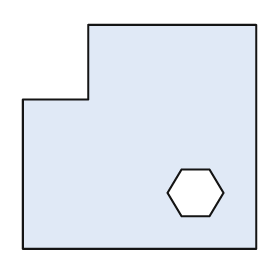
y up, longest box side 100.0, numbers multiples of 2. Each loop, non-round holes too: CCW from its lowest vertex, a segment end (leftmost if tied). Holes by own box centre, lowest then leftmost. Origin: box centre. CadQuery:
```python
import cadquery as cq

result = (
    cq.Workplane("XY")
    .moveTo(-50.0, -48.0)
    .lineTo(50.0, -48.0)
    .lineTo(50.0, 48.0)
    .lineTo(-22.0, 48.0)
    .lineTo(-22.0, 16.0)
    .lineTo(-50.0, 16.0)
    .close()
    .moveTo(18.0, -34.0)
    .lineTo(30.0, -34.0)
    .lineTo(36.0, -24.0)
    .lineTo(30.0, -14.0)
    .lineTo(18.0, -14.0)
    .lineTo(12.0, -24.0)
    .close()
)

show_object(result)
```